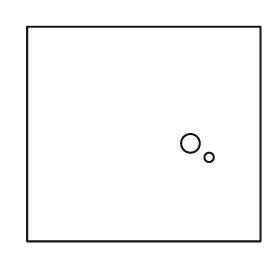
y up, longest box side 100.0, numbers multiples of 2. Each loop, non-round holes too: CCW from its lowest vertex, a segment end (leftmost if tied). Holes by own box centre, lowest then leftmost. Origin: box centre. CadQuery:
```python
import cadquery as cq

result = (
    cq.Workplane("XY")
    .moveTo(-50.0, -46.0)
    .lineTo(50.0, -46.0)
    .lineTo(50.0, 46.0)
    .lineTo(-50.0, 46.0)
    .close()
    .moveTo(28.0, -10.0)
    .circle(2.0)
    .moveTo(20.0, -4.0)
    .circle(4.0)
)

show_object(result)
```